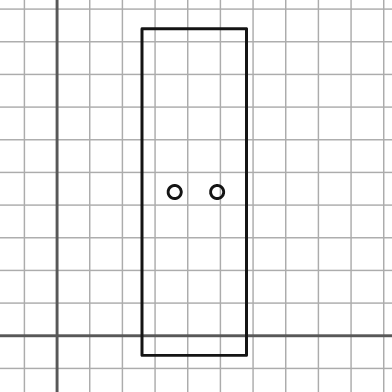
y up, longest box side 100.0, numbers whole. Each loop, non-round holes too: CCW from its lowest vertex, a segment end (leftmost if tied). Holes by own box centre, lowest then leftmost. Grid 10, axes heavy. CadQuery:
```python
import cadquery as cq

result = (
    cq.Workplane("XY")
    .moveTo(26.0, -6.0)
    .lineTo(58.0, -6.0)
    .lineTo(58.0, 94.0)
    .lineTo(26.0, 94.0)
    .close()
    .moveTo(36.0, 44.0)
    .circle(2.0)
    .moveTo(49.0, 44.0)
    .circle(2.0)
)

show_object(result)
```